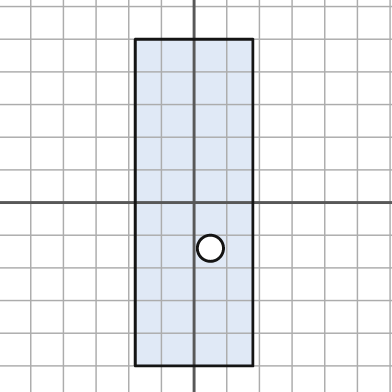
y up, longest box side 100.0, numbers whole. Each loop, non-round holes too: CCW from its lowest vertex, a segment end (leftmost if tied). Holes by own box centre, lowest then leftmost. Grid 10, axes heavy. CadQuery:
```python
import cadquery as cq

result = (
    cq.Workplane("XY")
    .moveTo(-18.0, -50.0)
    .lineTo(18.0, -50.0)
    .lineTo(18.0, 50.0)
    .lineTo(-18.0, 50.0)
    .close()
    .moveTo(5.0, -14.0)
    .circle(4.0)
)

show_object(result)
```